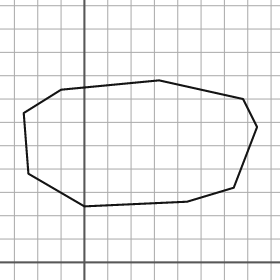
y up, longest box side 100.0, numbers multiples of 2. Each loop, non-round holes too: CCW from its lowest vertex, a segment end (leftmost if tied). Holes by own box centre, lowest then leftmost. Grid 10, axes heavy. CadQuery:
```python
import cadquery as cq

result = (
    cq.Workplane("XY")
    .moveTo(0.0, 24.0)
    .lineTo(44.0, 26.0)
    .lineTo(64.0, 32.0)
    .lineTo(74.0, 58.0)
    .lineTo(68.0, 70.0)
    .lineTo(32.0, 78.0)
    .lineTo(-10.0, 74.0)
    .lineTo(-26.0, 64.0)
    .lineTo(-24.0, 38.0)
    .close()
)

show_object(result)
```